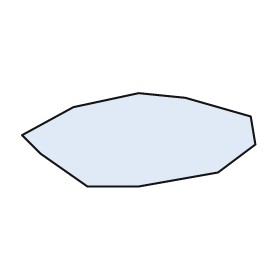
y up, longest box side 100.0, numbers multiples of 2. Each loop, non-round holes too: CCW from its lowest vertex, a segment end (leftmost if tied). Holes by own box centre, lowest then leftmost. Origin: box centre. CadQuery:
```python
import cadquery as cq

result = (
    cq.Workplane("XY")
    .moveTo(-22.0, -20.0)
    .lineTo(0.0, -20.0)
    .lineTo(34.0, -14.0)
    .lineTo(50.0, -2.0)
    .lineTo(48.0, 10.0)
    .lineTo(20.0, 18.0)
    .lineTo(0.0, 20.0)
    .lineTo(-28.0, 14.0)
    .lineTo(-50.0, 2.0)
    .lineTo(-42.0, -6.0)
    .close()
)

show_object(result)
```